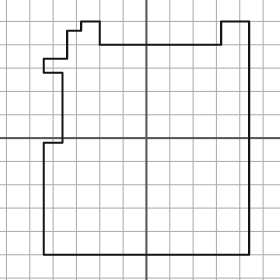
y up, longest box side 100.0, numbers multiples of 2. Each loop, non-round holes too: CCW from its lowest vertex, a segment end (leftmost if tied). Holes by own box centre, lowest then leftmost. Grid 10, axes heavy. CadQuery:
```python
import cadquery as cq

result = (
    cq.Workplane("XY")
    .moveTo(-44.0, -50.0)
    .lineTo(44.0, -50.0)
    .lineTo(44.0, 50.0)
    .lineTo(32.0, 50.0)
    .lineTo(32.0, 40.0)
    .lineTo(-20.0, 40.0)
    .lineTo(-20.0, 50.0)
    .lineTo(-28.0, 50.0)
    .lineTo(-28.0, 46.0)
    .lineTo(-34.0, 46.0)
    .lineTo(-34.0, 34.0)
    .lineTo(-44.0, 34.0)
    .lineTo(-44.0, 28.0)
    .lineTo(-36.0, 28.0)
    .lineTo(-36.0, -2.0)
    .lineTo(-44.0, -2.0)
    .close()
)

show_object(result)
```